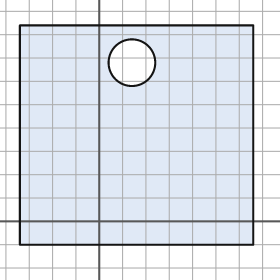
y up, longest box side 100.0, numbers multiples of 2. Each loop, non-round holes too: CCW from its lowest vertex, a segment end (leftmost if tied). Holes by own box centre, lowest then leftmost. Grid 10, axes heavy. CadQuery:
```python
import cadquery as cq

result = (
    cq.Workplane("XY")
    .moveTo(-34.0, -10.0)
    .lineTo(66.0, -10.0)
    .lineTo(66.0, 84.0)
    .lineTo(-34.0, 84.0)
    .close()
    .moveTo(14.0, 68.0)
    .circle(10.0)
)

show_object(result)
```